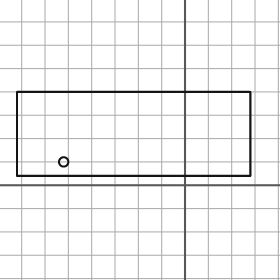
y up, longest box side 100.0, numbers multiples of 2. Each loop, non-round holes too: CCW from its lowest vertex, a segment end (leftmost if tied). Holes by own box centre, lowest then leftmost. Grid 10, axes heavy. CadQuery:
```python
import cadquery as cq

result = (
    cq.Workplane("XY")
    .moveTo(-72.0, 4.0)
    .lineTo(28.0, 4.0)
    .lineTo(28.0, 40.0)
    .lineTo(-72.0, 40.0)
    .close()
    .moveTo(-52.0, 10.0)
    .circle(2.0)
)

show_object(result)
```